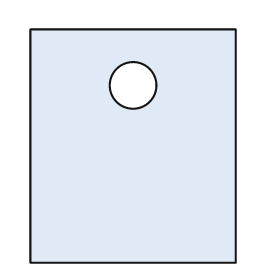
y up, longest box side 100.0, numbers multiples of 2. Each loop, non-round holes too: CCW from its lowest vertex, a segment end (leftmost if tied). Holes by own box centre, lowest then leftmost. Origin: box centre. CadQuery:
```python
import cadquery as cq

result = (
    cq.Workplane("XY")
    .moveTo(-44.0, -50.0)
    .lineTo(44.0, -50.0)
    .lineTo(44.0, 50.0)
    .lineTo(-44.0, 50.0)
    .close()
    .moveTo(0.0, 26.0)
    .circle(10.0)
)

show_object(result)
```